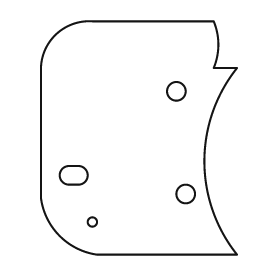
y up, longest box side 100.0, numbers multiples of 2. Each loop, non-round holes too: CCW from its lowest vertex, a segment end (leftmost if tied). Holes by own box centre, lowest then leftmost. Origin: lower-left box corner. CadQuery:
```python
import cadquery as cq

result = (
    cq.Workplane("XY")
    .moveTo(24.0, 0.0)
    .lineTo(84.0, 0.0)
    .threePointArc((70.0, 40.0), (84.0, 80.0))
    .lineTo(74.0, 80.0)
    .threePointArc((76.0, 90.0), (74.0, 100.0))
    .lineTo(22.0, 100.0)
    .threePointArc((6.0, 94.0), (0.0, 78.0))
    .lineTo(0.0, 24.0)
    .threePointArc((8.0, 8.0), (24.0, 0.0))
    .close()
    .moveTo(22.0, 14.0)
    .circle(2.0)
    .moveTo(62.0, 26.0)
    .circle(4.0)
    .moveTo(12.0, 30.0)
    .lineTo(16.0, 30.0)
    .threePointArc((20.0, 34.0), (16.0, 38.0))
    .lineTo(12.0, 38.0)
    .threePointArc((8.0, 34.0), (12.0, 30.0))
    .close()
    .moveTo(58.0, 70.0)
    .circle(4.0)
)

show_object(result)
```